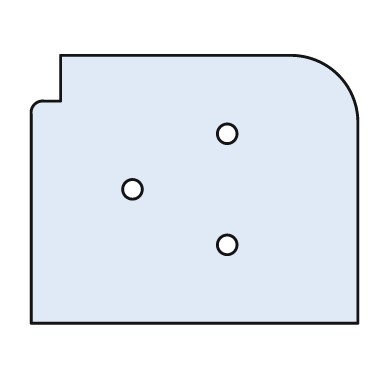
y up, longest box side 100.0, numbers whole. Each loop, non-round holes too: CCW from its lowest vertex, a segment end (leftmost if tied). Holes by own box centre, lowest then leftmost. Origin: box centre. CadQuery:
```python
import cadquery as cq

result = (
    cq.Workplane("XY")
    .moveTo(-50.0, -41.0)
    .lineTo(50.0, -41.0)
    .lineTo(50.0, 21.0)
    .threePointArc((44.0, 35.0), (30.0, 41.0))
    .lineTo(-41.0, 41.0)
    .lineTo(-41.0, 27.0)
    .lineTo(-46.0, 27.0)
    .threePointArc((-49.0, 26.0), (-50.0, 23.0))
    .close()
    .moveTo(10.0, -17.0)
    .circle(3.0)
    .moveTo(-19.0, 0.0)
    .circle(3.0)
    .moveTo(10.0, 17.0)
    .circle(3.0)
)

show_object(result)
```